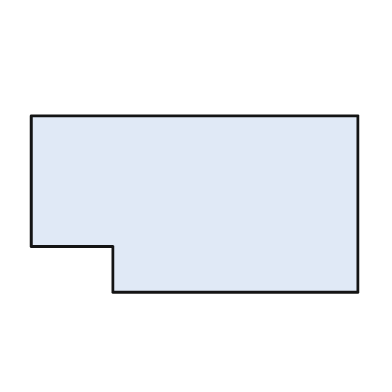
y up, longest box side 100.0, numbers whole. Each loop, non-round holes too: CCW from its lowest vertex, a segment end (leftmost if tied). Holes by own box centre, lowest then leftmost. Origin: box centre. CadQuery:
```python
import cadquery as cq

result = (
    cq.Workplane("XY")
    .moveTo(-25.0, -27.0)
    .lineTo(50.0, -27.0)
    .lineTo(50.0, 27.0)
    .lineTo(-50.0, 27.0)
    .lineTo(-50.0, -13.0)
    .lineTo(-25.0, -13.0)
    .close()
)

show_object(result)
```